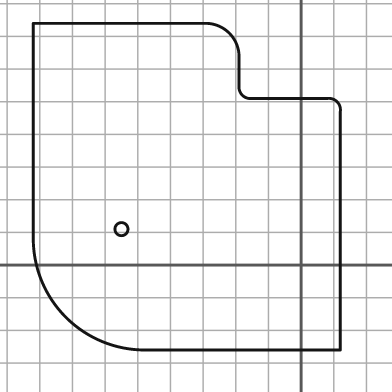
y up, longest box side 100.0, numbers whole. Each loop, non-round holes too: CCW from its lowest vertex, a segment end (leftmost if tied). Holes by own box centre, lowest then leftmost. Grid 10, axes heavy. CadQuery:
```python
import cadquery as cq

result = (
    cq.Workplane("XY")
    .moveTo(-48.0, -26.0)
    .lineTo(12.0, -26.0)
    .lineTo(12.0, 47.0)
    .threePointArc((11.0, 50.0), (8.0, 51.0))
    .lineTo(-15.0, 51.0)
    .threePointArc((-18.0, 52.0), (-19.0, 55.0))
    .lineTo(-19.0, 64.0)
    .threePointArc((-22.0, 71.0), (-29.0, 74.0))
    .lineTo(-82.0, 74.0)
    .lineTo(-82.0, 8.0)
    .threePointArc((-72.0, -16.0), (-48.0, -26.0))
    .close()
    .moveTo(-55.0, 11.0)
    .circle(2.0)
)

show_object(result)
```